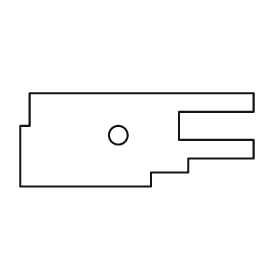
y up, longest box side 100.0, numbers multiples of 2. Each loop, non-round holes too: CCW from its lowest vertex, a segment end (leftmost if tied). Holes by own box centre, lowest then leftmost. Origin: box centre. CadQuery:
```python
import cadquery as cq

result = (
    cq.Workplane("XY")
    .moveTo(-50.0, -20.0)
    .lineTo(6.0, -20.0)
    .lineTo(6.0, -14.0)
    .lineTo(22.0, -14.0)
    .lineTo(22.0, -8.0)
    .lineTo(50.0, -8.0)
    .lineTo(50.0, 0.0)
    .lineTo(18.0, 0.0)
    .lineTo(18.0, 12.0)
    .lineTo(50.0, 12.0)
    .lineTo(50.0, 20.0)
    .lineTo(-46.0, 20.0)
    .lineTo(-46.0, 6.0)
    .lineTo(-50.0, 6.0)
    .close()
    .moveTo(-8.0, 2.0)
    .circle(4.0)
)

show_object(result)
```